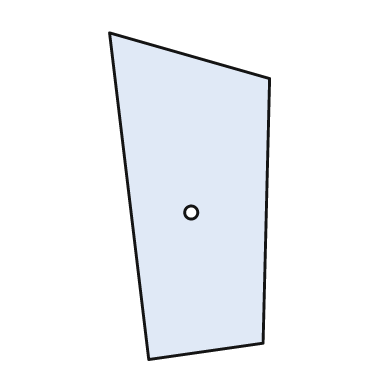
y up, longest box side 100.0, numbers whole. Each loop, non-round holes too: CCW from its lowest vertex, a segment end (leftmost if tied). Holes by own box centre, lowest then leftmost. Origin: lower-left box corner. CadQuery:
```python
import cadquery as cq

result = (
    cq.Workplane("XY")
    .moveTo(12.0, 0.0)
    .lineTo(47.0, 5.0)
    .lineTo(49.0, 86.0)
    .lineTo(0.0, 100.0)
    .close()
    .moveTo(25.0, 45.0)
    .circle(2.0)
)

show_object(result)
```